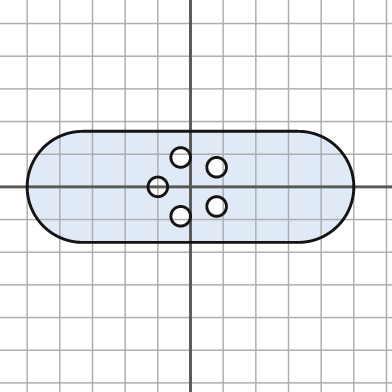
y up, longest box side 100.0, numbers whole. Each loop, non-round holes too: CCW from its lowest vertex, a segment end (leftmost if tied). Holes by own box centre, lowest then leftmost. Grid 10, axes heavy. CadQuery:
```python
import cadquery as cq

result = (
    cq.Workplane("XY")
    .moveTo(-33.0, -17.0)
    .lineTo(33.0, -17.0)
    .threePointArc((50.0, 0.0), (33.0, 17.0))
    .lineTo(-33.0, 17.0)
    .threePointArc((-50.0, 0.0), (-33.0, -17.0))
    .close()
    .moveTo(-3.0, -9.0)
    .circle(3.0)
    .moveTo(8.0, -6.0)
    .circle(3.0)
    .moveTo(-10.0, 0.0)
    .circle(3.0)
    .moveTo(8.0, 6.0)
    .circle(3.0)
    .moveTo(-3.0, 9.0)
    .circle(3.0)
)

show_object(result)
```